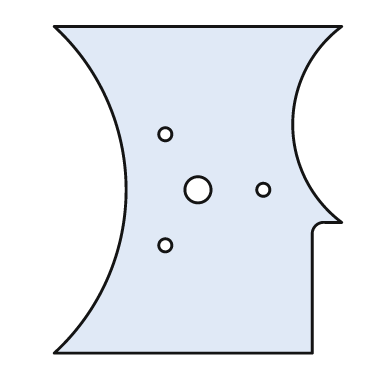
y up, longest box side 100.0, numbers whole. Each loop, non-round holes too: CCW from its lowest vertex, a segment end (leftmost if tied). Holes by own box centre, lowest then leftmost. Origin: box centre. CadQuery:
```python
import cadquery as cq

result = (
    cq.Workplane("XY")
    .moveTo(-44.0, -50.0)
    .lineTo(35.0, -50.0)
    .lineTo(35.0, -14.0)
    .threePointArc((36.0, -11.0), (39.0, -10.0))
    .lineTo(44.0, -10.0)
    .threePointArc((29.0, 20.0), (44.0, 50.0))
    .lineTo(-44.0, 50.0)
    .threePointArc((-22.0, 0.0), (-44.0, -50.0))
    .close()
    .moveTo(-10.0, -17.0)
    .circle(2.0)
    .moveTo(0.0, 0.0)
    .circle(4.0)
    .moveTo(20.0, 0.0)
    .circle(2.0)
    .moveTo(-10.0, 17.0)
    .circle(2.0)
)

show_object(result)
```